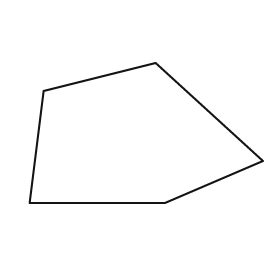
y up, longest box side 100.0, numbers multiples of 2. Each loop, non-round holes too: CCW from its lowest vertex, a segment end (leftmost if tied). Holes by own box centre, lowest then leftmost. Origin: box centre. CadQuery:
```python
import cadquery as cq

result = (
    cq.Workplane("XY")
    .moveTo(-50.0, -30.0)
    .lineTo(8.0, -30.0)
    .lineTo(50.0, -12.0)
    .lineTo(4.0, 30.0)
    .lineTo(-44.0, 18.0)
    .close()
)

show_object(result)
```